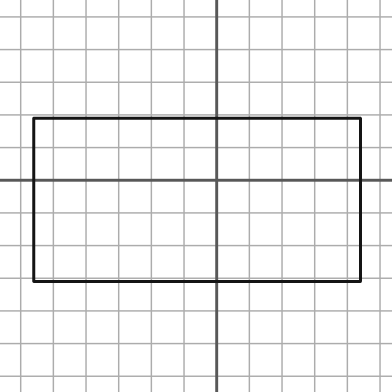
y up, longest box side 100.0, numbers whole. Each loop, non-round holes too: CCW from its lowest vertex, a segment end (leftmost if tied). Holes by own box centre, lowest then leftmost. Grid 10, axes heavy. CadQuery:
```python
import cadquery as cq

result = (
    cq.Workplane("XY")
    .moveTo(-56.0, -31.0)
    .lineTo(44.0, -31.0)
    .lineTo(44.0, 19.0)
    .lineTo(-56.0, 19.0)
    .close()
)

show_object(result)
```